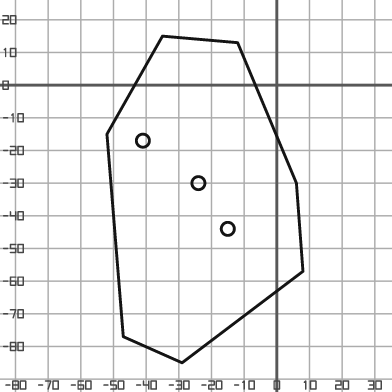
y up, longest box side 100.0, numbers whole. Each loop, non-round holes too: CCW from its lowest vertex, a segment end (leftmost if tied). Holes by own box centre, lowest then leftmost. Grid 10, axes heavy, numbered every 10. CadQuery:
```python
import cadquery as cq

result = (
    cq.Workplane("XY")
    .moveTo(-29.0, -85.0)
    .lineTo(8.0, -57.0)
    .lineTo(6.0, -30.0)
    .lineTo(-12.0, 13.0)
    .lineTo(-35.0, 15.0)
    .lineTo(-52.0, -15.0)
    .lineTo(-47.0, -77.0)
    .close()
    .moveTo(-15.0, -44.0)
    .circle(2.0)
    .moveTo(-24.0, -30.0)
    .circle(2.0)
    .moveTo(-41.0, -17.0)
    .circle(2.0)
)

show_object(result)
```